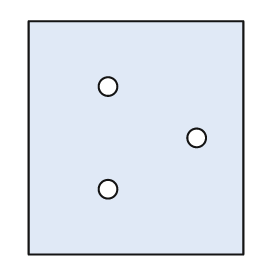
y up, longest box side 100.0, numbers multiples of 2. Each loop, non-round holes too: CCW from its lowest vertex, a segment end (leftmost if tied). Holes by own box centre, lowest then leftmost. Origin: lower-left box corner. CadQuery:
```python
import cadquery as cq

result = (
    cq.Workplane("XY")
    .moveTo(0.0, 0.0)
    .lineTo(92.0, 0.0)
    .lineTo(92.0, 100.0)
    .lineTo(0.0, 100.0)
    .close()
    .moveTo(34.0, 28.0)
    .circle(4.0)
    .moveTo(72.0, 50.0)
    .circle(4.0)
    .moveTo(34.0, 72.0)
    .circle(4.0)
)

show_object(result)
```